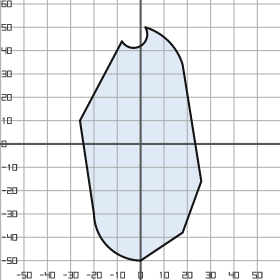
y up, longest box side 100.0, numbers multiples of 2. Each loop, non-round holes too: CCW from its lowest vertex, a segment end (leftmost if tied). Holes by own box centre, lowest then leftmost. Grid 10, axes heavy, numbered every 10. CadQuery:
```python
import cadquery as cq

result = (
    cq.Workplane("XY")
    .moveTo(0.0, -50.0)
    .lineTo(18.0, -38.0)
    .lineTo(26.0, -16.0)
    .lineTo(18.0, 34.0)
    .threePointArc((12.0, 44.0), (2.0, 50.0))
    .threePointArc((0.0, 42.0), (-8.0, 44.0))
    .lineTo(-26.0, 10.0)
    .lineTo(-20.0, -30.0)
    .threePointArc((-14.0, -44.0), (0.0, -50.0))
    .close()
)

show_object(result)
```